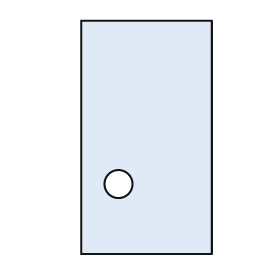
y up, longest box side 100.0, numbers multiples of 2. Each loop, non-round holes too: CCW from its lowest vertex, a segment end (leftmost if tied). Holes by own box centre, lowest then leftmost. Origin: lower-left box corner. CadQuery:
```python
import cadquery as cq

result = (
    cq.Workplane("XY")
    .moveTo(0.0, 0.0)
    .lineTo(56.0, 0.0)
    .lineTo(56.0, 100.0)
    .lineTo(0.0, 100.0)
    .close()
    .moveTo(16.0, 30.0)
    .circle(6.0)
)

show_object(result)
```